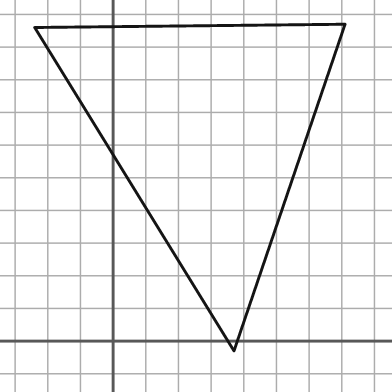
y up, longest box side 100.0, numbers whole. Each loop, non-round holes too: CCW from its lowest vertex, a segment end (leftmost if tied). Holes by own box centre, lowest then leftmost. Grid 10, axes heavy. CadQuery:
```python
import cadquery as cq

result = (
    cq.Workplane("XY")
    .moveTo(37.0, -3.0)
    .lineTo(71.0, 97.0)
    .lineTo(-24.0, 96.0)
    .close()
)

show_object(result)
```